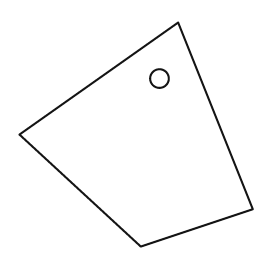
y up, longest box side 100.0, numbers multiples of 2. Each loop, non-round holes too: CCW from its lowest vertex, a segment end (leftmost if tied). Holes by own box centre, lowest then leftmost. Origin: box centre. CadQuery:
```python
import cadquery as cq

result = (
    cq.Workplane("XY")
    .moveTo(2.0, -48.0)
    .lineTo(50.0, -32.0)
    .lineTo(18.0, 48.0)
    .lineTo(-50.0, 0.0)
    .close()
    .moveTo(10.0, 24.0)
    .circle(4.0)
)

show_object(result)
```